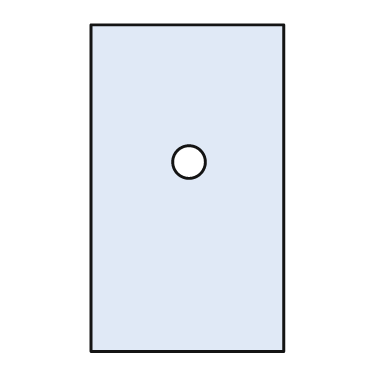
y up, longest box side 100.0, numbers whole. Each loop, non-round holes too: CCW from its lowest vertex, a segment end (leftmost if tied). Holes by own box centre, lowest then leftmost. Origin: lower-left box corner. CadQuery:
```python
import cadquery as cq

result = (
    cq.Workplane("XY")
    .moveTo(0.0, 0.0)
    .lineTo(59.0, 0.0)
    .lineTo(59.0, 100.0)
    .lineTo(0.0, 100.0)
    .close()
    .moveTo(30.0, 58.0)
    .circle(5.0)
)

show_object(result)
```